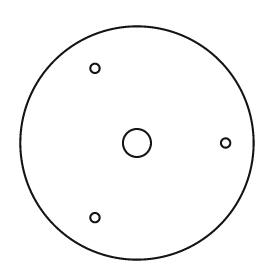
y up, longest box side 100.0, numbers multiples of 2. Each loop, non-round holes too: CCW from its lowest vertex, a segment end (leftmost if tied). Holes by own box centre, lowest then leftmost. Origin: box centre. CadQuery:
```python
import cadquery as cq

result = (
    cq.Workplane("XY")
    .moveTo(0.0, 0.0)
    .circle(50.0)
    .moveTo(-18.0, -32.0)
    .circle(2.0)
    .moveTo(0.0, 0.0)
    .circle(6.0)
    .moveTo(38.0, 0.0)
    .circle(2.0)
    .moveTo(-18.0, 32.0)
    .circle(2.0)
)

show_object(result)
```